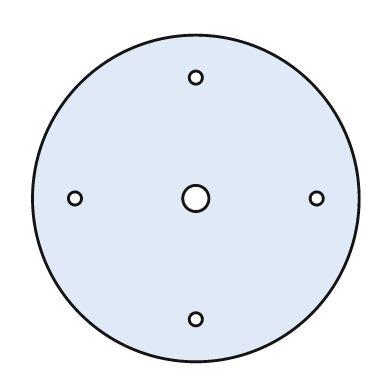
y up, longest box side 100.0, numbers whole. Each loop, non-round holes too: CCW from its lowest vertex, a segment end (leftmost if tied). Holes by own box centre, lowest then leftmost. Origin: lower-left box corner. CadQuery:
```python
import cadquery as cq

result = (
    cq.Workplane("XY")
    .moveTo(50.0, 50.0)
    .circle(50.0)
    .moveTo(50.0, 13.0)
    .circle(2.0)
    .moveTo(13.0, 50.0)
    .circle(2.0)
    .moveTo(50.0, 50.0)
    .circle(4.0)
    .moveTo(87.0, 50.0)
    .circle(2.0)
    .moveTo(50.0, 87.0)
    .circle(2.0)
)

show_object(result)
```